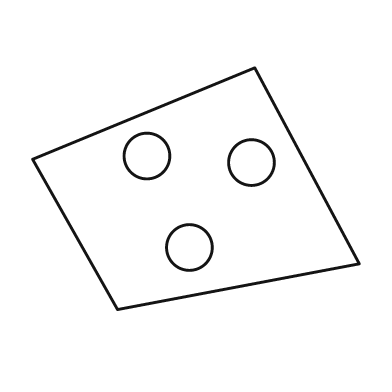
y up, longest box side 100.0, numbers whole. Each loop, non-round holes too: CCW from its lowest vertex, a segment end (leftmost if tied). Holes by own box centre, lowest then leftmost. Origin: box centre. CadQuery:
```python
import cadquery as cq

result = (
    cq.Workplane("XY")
    .moveTo(-24.0, -37.0)
    .lineTo(50.0, -23.0)
    .lineTo(18.0, 37.0)
    .lineTo(-50.0, 9.0)
    .close()
    .moveTo(-2.0, -18.0)
    .circle(7.0)
    .moveTo(17.0, 8.0)
    .circle(7.0)
    .moveTo(-15.0, 10.0)
    .circle(7.0)
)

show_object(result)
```